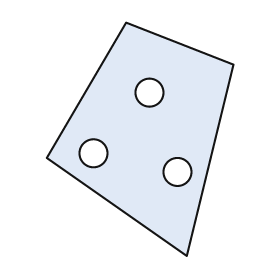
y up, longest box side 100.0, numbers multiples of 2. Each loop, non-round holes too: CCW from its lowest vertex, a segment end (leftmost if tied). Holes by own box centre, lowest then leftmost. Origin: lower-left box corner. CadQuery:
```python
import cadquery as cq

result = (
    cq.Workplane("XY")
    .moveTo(60.0, 0.0)
    .lineTo(80.0, 82.0)
    .lineTo(34.0, 100.0)
    .lineTo(0.0, 42.0)
    .close()
    .moveTo(56.0, 36.0)
    .circle(6.0)
    .moveTo(20.0, 44.0)
    .circle(6.0)
    .moveTo(44.0, 70.0)
    .circle(6.0)
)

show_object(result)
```